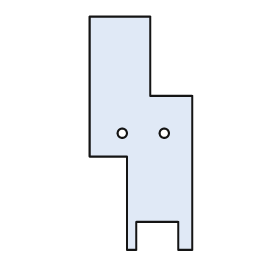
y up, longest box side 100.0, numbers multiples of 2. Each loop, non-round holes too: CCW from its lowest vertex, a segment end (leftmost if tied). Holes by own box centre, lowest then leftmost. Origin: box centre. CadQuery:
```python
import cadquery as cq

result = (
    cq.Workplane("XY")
    .moveTo(-6.0, -50.0)
    .lineTo(-2.0, -50.0)
    .lineTo(-2.0, -38.0)
    .lineTo(16.0, -38.0)
    .lineTo(16.0, -50.0)
    .lineTo(22.0, -50.0)
    .lineTo(22.0, 16.0)
    .lineTo(4.0, 16.0)
    .lineTo(4.0, 50.0)
    .lineTo(-22.0, 50.0)
    .lineTo(-22.0, -10.0)
    .lineTo(-6.0, -10.0)
    .close()
    .moveTo(-8.0, 0.0)
    .circle(2.0)
    .moveTo(10.0, 0.0)
    .circle(2.0)
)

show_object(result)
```